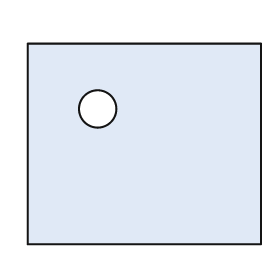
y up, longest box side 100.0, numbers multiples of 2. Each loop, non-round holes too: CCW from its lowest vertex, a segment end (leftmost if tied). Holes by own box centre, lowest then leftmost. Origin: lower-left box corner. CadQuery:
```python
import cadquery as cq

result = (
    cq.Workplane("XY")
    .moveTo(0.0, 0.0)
    .lineTo(100.0, 0.0)
    .lineTo(100.0, 86.0)
    .lineTo(0.0, 86.0)
    .close()
    .moveTo(30.0, 58.0)
    .circle(8.0)
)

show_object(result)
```